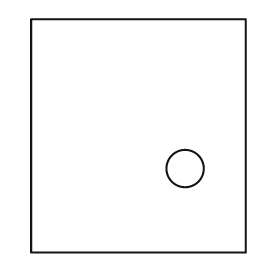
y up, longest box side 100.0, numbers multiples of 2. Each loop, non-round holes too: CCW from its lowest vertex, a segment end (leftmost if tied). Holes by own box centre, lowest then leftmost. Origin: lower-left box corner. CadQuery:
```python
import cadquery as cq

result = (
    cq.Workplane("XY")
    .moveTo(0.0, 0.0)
    .lineTo(92.0, 0.0)
    .lineTo(92.0, 100.0)
    .lineTo(0.0, 100.0)
    .close()
    .moveTo(66.0, 36.0)
    .circle(8.0)
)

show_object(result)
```